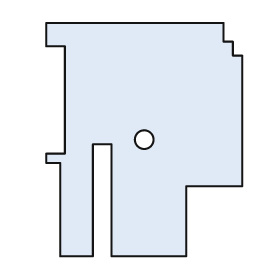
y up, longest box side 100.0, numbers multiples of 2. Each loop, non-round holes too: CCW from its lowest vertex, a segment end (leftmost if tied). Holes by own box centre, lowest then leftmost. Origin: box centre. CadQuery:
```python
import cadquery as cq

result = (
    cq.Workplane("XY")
    .moveTo(-36.0, -50.0)
    .lineTo(-22.0, -50.0)
    .lineTo(-22.0, -2.0)
    .lineTo(-14.0, -2.0)
    .lineTo(-14.0, -50.0)
    .lineTo(18.0, -50.0)
    .lineTo(18.0, -20.0)
    .lineTo(42.0, -20.0)
    .lineTo(42.0, 36.0)
    .lineTo(38.0, 36.0)
    .lineTo(38.0, 42.0)
    .lineTo(34.0, 42.0)
    .lineTo(34.0, 50.0)
    .lineTo(-42.0, 50.0)
    .lineTo(-42.0, 40.0)
    .lineTo(-34.0, 40.0)
    .lineTo(-34.0, -6.0)
    .lineTo(-42.0, -6.0)
    .lineTo(-42.0, -10.0)
    .lineTo(-36.0, -10.0)
    .close()
    .moveTo(0.0, 0.0)
    .circle(4.0)
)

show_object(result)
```